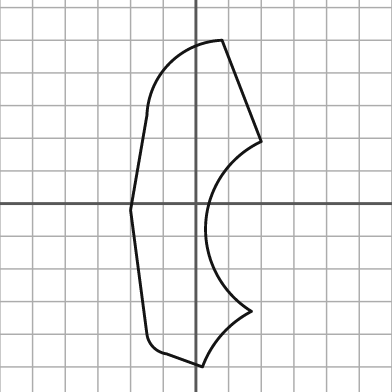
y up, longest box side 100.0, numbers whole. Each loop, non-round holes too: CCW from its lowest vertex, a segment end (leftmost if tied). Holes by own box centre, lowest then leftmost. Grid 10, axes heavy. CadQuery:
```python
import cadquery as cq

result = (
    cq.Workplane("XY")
    .moveTo(2.0, -50.0)
    .threePointArc((8.0, -40.0), (17.0, -33.0))
    .threePointArc((3.0, -6.0), (20.0, 19.0))
    .lineTo(8.0, 50.0)
    .threePointArc((-8.0, 43.0), (-15.0, 27.0))
    .lineTo(-20.0, -2.0)
    .lineTo(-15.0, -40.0)
    .threePointArc((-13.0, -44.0), (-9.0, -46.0))
    .close()
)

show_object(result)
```